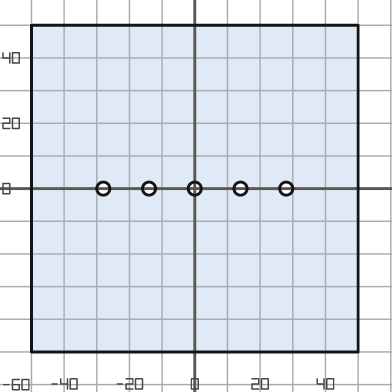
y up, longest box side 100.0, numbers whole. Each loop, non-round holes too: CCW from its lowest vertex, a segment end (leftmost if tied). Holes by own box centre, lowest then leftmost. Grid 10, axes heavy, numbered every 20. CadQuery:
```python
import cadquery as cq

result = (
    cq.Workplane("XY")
    .moveTo(-50.0, -50.0)
    .lineTo(50.0, -50.0)
    .lineTo(50.0, 50.0)
    .lineTo(-50.0, 50.0)
    .close()
    .moveTo(-28.0, 0.0)
    .circle(2.0)
    .moveTo(-14.0, 0.0)
    .circle(2.0)
    .moveTo(0.0, 0.0)
    .circle(2.0)
    .moveTo(14.0, 0.0)
    .circle(2.0)
    .moveTo(28.0, 0.0)
    .circle(2.0)
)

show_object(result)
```